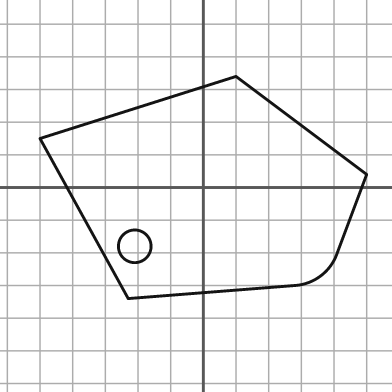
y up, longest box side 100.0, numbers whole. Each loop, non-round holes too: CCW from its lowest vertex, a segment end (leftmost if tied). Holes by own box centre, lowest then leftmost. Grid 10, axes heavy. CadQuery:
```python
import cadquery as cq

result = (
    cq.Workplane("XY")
    .moveTo(-23.0, -34.0)
    .lineTo(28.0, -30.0)
    .threePointArc((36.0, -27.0), (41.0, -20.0))
    .lineTo(50.0, 4.0)
    .lineTo(10.0, 34.0)
    .lineTo(-50.0, 15.0)
    .close()
    .moveTo(-21.0, -18.0)
    .circle(5.0)
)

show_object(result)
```